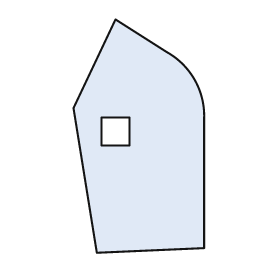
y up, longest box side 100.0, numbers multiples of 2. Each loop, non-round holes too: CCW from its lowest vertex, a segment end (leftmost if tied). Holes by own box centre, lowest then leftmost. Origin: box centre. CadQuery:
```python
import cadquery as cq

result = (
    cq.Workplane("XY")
    .moveTo(-18.0, -50.0)
    .lineTo(28.0, -48.0)
    .lineTo(28.0, 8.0)
    .threePointArc((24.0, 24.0), (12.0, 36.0))
    .lineTo(-10.0, 50.0)
    .lineTo(-28.0, 12.0)
    .close()
    .moveTo(-16.0, -4.0)
    .lineTo(-4.0, -4.0)
    .lineTo(-4.0, 8.0)
    .lineTo(-16.0, 8.0)
    .close()
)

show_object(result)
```